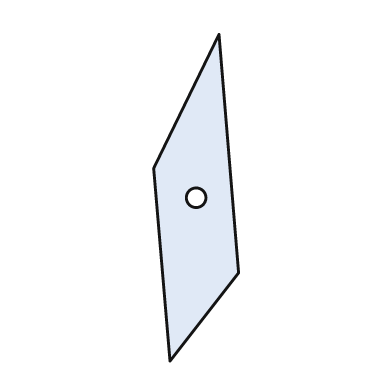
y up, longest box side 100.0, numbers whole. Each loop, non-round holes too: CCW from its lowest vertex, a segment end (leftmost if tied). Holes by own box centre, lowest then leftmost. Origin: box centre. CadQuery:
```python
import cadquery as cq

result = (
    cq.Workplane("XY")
    .moveTo(-8.0, -50.0)
    .lineTo(13.0, -23.0)
    .lineTo(7.0, 50.0)
    .lineTo(-13.0, 9.0)
    .close()
    .moveTo(0.0, 0.0)
    .circle(3.0)
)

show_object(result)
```